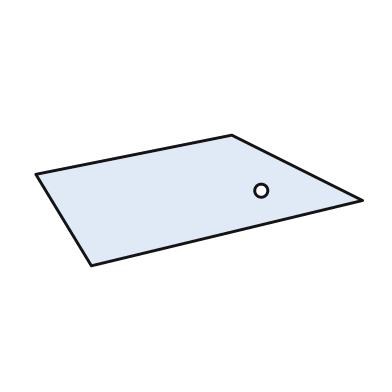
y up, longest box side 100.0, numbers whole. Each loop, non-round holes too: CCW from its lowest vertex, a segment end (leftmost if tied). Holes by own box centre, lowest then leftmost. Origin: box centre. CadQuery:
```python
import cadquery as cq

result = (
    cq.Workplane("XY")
    .moveTo(-33.0, -20.0)
    .lineTo(50.0, 0.0)
    .lineTo(10.0, 20.0)
    .lineTo(-50.0, 8.0)
    .close()
    .moveTo(19.0, 3.0)
    .circle(2.0)
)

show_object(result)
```